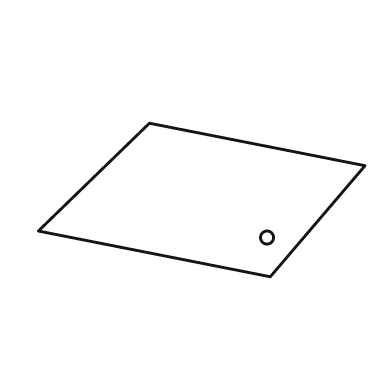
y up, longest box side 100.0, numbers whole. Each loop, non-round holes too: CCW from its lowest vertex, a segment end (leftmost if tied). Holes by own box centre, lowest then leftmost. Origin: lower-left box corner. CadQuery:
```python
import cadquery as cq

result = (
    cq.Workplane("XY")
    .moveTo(71.0, 0.0)
    .lineTo(100.0, 34.0)
    .lineTo(34.0, 47.0)
    .lineTo(0.0, 14.0)
    .close()
    .moveTo(70.0, 12.0)
    .circle(2.0)
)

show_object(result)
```